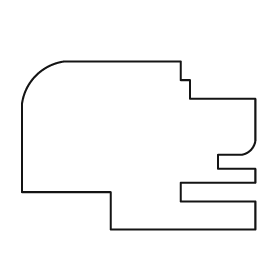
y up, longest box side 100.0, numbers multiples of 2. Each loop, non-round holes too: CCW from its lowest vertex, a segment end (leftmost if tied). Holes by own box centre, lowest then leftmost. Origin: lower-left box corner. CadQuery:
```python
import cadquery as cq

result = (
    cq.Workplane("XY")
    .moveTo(38.0, 0.0)
    .lineTo(100.0, 0.0)
    .lineTo(100.0, 12.0)
    .lineTo(68.0, 12.0)
    .lineTo(68.0, 20.0)
    .lineTo(100.0, 20.0)
    .lineTo(100.0, 26.0)
    .lineTo(84.0, 26.0)
    .lineTo(84.0, 32.0)
    .lineTo(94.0, 32.0)
    .threePointArc((98.0, 34.0), (100.0, 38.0))
    .lineTo(100.0, 56.0)
    .lineTo(72.0, 56.0)
    .lineTo(72.0, 64.0)
    .lineTo(68.0, 64.0)
    .lineTo(68.0, 72.0)
    .lineTo(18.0, 72.0)
    .threePointArc((6.0, 66.0), (0.0, 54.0))
    .lineTo(0.0, 16.0)
    .lineTo(38.0, 16.0)
    .close()
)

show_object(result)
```